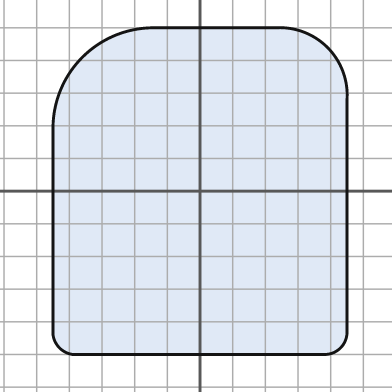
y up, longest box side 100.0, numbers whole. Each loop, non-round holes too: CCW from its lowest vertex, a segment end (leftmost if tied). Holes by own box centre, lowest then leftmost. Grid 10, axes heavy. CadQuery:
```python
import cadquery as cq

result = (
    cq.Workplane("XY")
    .moveTo(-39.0, -50.0)
    .lineTo(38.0, -50.0)
    .threePointArc((43.0, -48.0), (45.0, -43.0))
    .lineTo(45.0, 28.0)
    .threePointArc((39.0, 44.0), (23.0, 50.0))
    .lineTo(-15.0, 50.0)
    .threePointArc((-36.0, 41.0), (-45.0, 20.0))
    .lineTo(-45.0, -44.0)
    .threePointArc((-43.0, -48.0), (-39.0, -50.0))
    .close()
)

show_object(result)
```